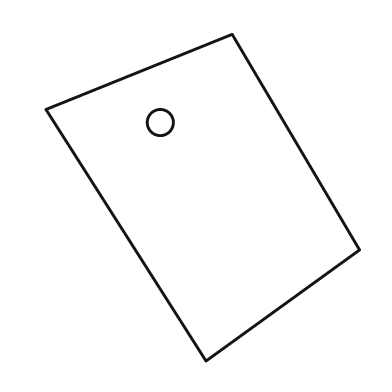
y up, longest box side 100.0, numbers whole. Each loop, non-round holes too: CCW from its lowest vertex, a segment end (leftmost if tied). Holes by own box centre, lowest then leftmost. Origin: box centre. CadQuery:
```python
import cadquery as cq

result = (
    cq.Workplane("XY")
    .moveTo(1.0, -50.0)
    .lineTo(48.0, -16.0)
    .lineTo(9.0, 50.0)
    .lineTo(-48.0, 27.0)
    .close()
    .moveTo(-13.0, 23.0)
    .circle(4.0)
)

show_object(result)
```